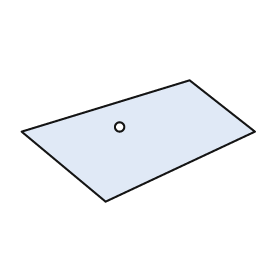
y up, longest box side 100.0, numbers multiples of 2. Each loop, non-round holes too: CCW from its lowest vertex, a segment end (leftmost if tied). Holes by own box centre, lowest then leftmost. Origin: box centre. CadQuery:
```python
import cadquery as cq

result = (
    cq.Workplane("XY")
    .moveTo(-14.0, -26.0)
    .lineTo(50.0, 4.0)
    .lineTo(22.0, 26.0)
    .lineTo(-50.0, 4.0)
    .close()
    .moveTo(-8.0, 6.0)
    .circle(2.0)
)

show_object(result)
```